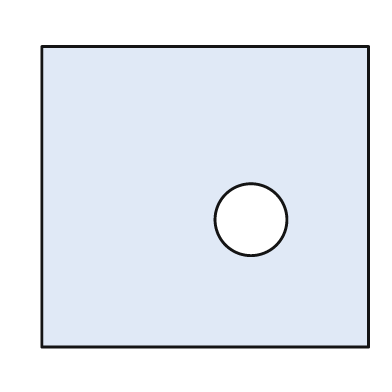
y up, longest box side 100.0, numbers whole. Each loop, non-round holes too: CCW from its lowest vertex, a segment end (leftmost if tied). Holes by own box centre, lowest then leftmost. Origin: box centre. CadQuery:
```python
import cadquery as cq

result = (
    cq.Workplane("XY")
    .moveTo(-50.0, -46.0)
    .lineTo(50.0, -46.0)
    .lineTo(50.0, 46.0)
    .lineTo(-50.0, 46.0)
    .close()
    .moveTo(14.0, -7.0)
    .circle(11.0)
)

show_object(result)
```